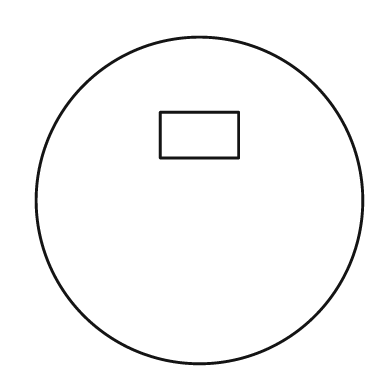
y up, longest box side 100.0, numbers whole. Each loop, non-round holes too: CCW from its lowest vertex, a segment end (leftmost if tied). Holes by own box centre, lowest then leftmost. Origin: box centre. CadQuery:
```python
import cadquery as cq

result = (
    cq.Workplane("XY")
    .moveTo(0.0, 0.0)
    .circle(50.0)
    .moveTo(-12.0, 13.0)
    .lineTo(12.0, 13.0)
    .lineTo(12.0, 27.0)
    .lineTo(-12.0, 27.0)
    .close()
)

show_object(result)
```